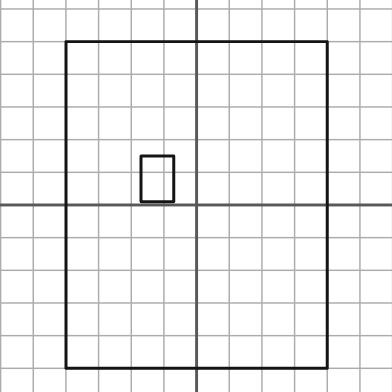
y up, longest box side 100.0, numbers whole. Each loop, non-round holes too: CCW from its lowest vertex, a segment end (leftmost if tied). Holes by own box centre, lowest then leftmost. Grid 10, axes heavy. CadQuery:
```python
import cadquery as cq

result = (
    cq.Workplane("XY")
    .moveTo(-40.0, -50.0)
    .lineTo(40.0, -50.0)
    .lineTo(40.0, 50.0)
    .lineTo(-40.0, 50.0)
    .close()
    .moveTo(-17.0, 1.0)
    .lineTo(-7.0, 1.0)
    .lineTo(-7.0, 15.0)
    .lineTo(-17.0, 15.0)
    .close()
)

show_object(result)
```